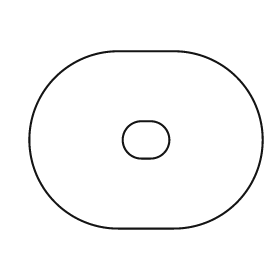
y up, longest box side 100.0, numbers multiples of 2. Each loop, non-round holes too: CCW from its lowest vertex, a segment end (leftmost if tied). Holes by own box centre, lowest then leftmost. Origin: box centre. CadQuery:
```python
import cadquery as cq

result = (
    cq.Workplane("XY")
    .moveTo(-12.0, -38.0)
    .lineTo(12.0, -38.0)
    .threePointArc((50.0, 0.0), (12.0, 38.0))
    .lineTo(-12.0, 38.0)
    .threePointArc((-50.0, 0.0), (-12.0, -38.0))
    .close()
    .moveTo(-2.0, -8.0)
    .lineTo(2.0, -8.0)
    .threePointArc((10.0, 0.0), (2.0, 8.0))
    .lineTo(-2.0, 8.0)
    .threePointArc((-10.0, 0.0), (-2.0, -8.0))
    .close()
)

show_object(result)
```